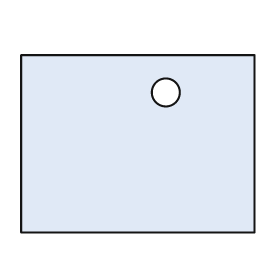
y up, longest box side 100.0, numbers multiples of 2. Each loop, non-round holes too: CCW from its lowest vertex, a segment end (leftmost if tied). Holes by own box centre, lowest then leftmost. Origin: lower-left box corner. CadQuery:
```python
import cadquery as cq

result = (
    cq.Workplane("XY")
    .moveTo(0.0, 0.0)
    .lineTo(100.0, 0.0)
    .lineTo(100.0, 76.0)
    .lineTo(0.0, 76.0)
    .close()
    .moveTo(62.0, 60.0)
    .circle(6.0)
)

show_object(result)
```